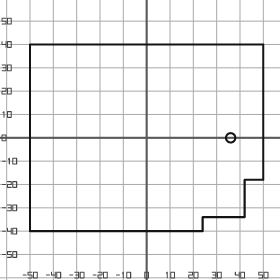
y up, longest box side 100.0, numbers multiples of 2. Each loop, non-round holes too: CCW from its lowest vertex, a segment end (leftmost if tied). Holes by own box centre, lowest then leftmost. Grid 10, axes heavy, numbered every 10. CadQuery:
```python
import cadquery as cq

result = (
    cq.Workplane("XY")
    .moveTo(-50.0, -40.0)
    .lineTo(24.0, -40.0)
    .lineTo(24.0, -34.0)
    .lineTo(42.0, -34.0)
    .lineTo(42.0, -18.0)
    .lineTo(50.0, -18.0)
    .lineTo(50.0, 40.0)
    .lineTo(-50.0, 40.0)
    .close()
    .moveTo(36.0, 0.0)
    .circle(2.0)
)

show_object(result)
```